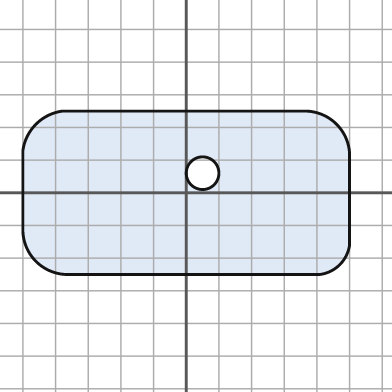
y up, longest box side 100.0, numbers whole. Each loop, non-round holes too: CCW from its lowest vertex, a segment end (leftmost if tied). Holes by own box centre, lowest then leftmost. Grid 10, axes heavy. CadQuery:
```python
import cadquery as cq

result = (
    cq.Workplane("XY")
    .moveTo(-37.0, -25.0)
    .lineTo(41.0, -25.0)
    .threePointArc((47.0, -22.0), (50.0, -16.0))
    .lineTo(50.0, 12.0)
    .threePointArc((46.0, 21.0), (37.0, 25.0))
    .lineTo(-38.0, 25.0)
    .threePointArc((-46.0, 21.0), (-50.0, 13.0))
    .lineTo(-50.0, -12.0)
    .threePointArc((-46.0, -21.0), (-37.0, -25.0))
    .close()
    .moveTo(5.0, 6.0)
    .circle(5.0)
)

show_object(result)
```